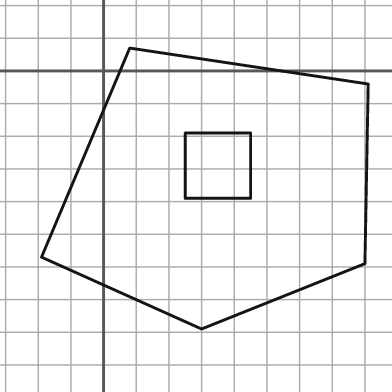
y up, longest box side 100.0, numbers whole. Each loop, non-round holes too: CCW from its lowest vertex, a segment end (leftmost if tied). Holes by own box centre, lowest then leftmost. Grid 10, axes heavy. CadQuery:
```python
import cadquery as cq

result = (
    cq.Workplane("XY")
    .moveTo(30.0, -79.0)
    .lineTo(80.0, -59.0)
    .lineTo(81.0, -4.0)
    .lineTo(8.0, 7.0)
    .lineTo(-19.0, -57.0)
    .close()
    .moveTo(25.0, -39.0)
    .lineTo(45.0, -39.0)
    .lineTo(45.0, -19.0)
    .lineTo(25.0, -19.0)
    .close()
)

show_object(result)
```